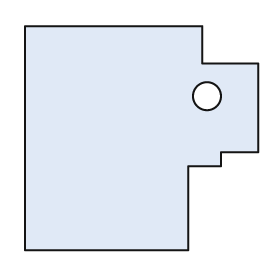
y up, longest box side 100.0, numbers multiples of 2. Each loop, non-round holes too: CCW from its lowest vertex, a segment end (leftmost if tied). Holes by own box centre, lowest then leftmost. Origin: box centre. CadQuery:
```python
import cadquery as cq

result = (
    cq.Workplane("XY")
    .moveTo(-50.0, -48.0)
    .lineTo(20.0, -48.0)
    .lineTo(20.0, -12.0)
    .lineTo(34.0, -12.0)
    .lineTo(34.0, -6.0)
    .lineTo(50.0, -6.0)
    .lineTo(50.0, 32.0)
    .lineTo(26.0, 32.0)
    .lineTo(26.0, 48.0)
    .lineTo(-50.0, 48.0)
    .close()
    .moveTo(28.0, 18.0)
    .circle(6.0)
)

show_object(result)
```